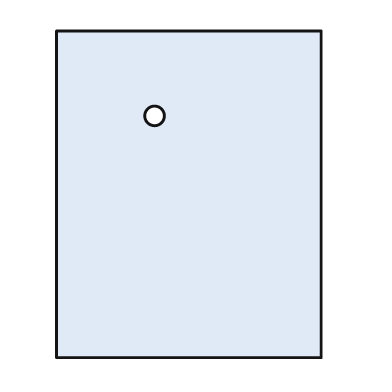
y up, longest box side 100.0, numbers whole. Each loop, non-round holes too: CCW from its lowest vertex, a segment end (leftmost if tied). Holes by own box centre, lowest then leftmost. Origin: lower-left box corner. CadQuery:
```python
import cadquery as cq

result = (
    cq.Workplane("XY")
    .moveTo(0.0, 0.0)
    .lineTo(81.0, 0.0)
    .lineTo(81.0, 100.0)
    .lineTo(0.0, 100.0)
    .close()
    .moveTo(30.0, 74.0)
    .circle(3.0)
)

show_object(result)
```